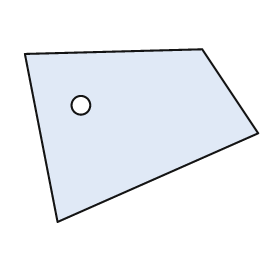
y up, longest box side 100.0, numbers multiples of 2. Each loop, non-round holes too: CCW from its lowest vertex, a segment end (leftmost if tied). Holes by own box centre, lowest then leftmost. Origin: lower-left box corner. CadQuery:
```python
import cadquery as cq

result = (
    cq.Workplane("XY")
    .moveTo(14.0, 0.0)
    .lineTo(100.0, 38.0)
    .lineTo(76.0, 74.0)
    .lineTo(0.0, 72.0)
    .close()
    .moveTo(24.0, 50.0)
    .circle(4.0)
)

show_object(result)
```